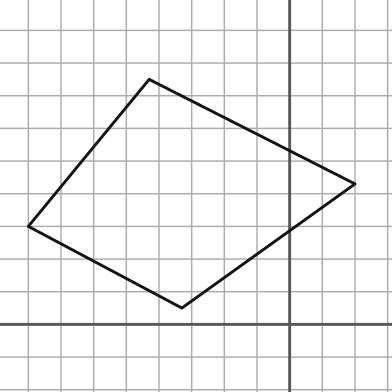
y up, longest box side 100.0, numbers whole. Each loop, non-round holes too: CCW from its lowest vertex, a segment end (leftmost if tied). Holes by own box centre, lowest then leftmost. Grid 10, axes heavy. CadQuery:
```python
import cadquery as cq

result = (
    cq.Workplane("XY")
    .moveTo(-33.0, 5.0)
    .lineTo(20.0, 43.0)
    .lineTo(-43.0, 75.0)
    .lineTo(-80.0, 30.0)
    .close()
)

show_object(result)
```